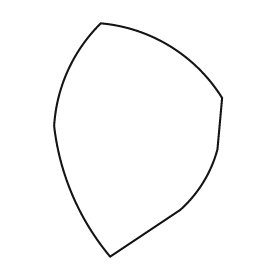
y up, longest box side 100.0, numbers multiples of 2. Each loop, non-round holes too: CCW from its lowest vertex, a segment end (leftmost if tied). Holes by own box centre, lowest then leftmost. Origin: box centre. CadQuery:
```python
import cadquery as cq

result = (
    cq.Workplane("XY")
    .moveTo(-12.0, -50.0)
    .lineTo(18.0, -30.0)
    .threePointArc((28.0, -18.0), (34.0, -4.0))
    .lineTo(36.0, 18.0)
    .threePointArc((14.0, 40.0), (-16.0, 50.0))
    .threePointArc((-30.0, 30.0), (-36.0, 6.0))
    .threePointArc((-28.0, -24.0), (-12.0, -50.0))
    .close()
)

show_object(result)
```